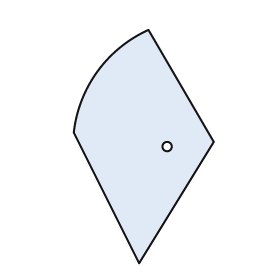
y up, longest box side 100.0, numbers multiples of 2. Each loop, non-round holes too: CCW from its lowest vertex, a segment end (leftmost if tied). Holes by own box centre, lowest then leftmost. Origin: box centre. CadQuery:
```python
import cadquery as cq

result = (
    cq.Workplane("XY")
    .moveTo(-2.0, -50.0)
    .lineTo(30.0, 2.0)
    .lineTo(2.0, 50.0)
    .threePointArc((-20.0, 32.0), (-30.0, 6.0))
    .close()
    .moveTo(10.0, 0.0)
    .circle(2.0)
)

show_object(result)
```